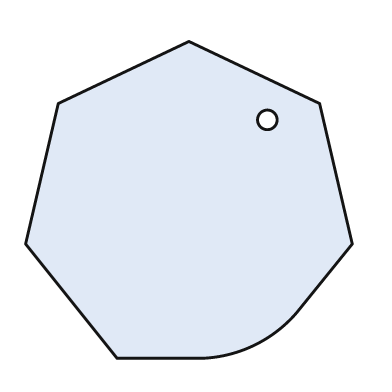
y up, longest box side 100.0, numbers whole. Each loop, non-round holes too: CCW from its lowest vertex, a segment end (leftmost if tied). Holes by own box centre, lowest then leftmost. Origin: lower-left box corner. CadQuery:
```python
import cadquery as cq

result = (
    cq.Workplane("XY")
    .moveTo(28.0, 0.0)
    .lineTo(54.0, 0.0)
    .threePointArc((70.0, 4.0), (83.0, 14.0))
    .lineTo(100.0, 35.0)
    .lineTo(90.0, 78.0)
    .lineTo(50.0, 97.0)
    .lineTo(10.0, 78.0)
    .lineTo(0.0, 35.0)
    .close()
    .moveTo(74.0, 73.0)
    .circle(3.0)
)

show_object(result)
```